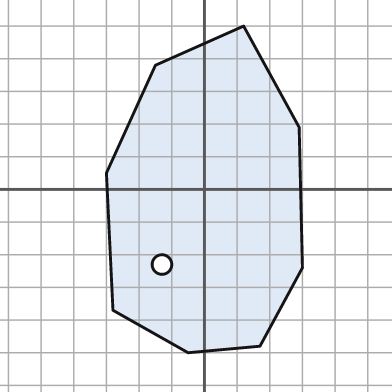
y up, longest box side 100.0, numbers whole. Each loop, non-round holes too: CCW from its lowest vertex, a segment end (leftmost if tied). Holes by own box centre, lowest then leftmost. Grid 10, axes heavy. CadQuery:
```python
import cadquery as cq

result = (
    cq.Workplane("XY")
    .moveTo(-5.0, -50.0)
    .lineTo(17.0, -48.0)
    .lineTo(30.0, -24.0)
    .lineTo(29.0, 19.0)
    .lineTo(12.0, 50.0)
    .lineTo(-15.0, 38.0)
    .lineTo(-30.0, 5.0)
    .lineTo(-28.0, -37.0)
    .close()
    .moveTo(-13.0, -23.0)
    .circle(3.0)
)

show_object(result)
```